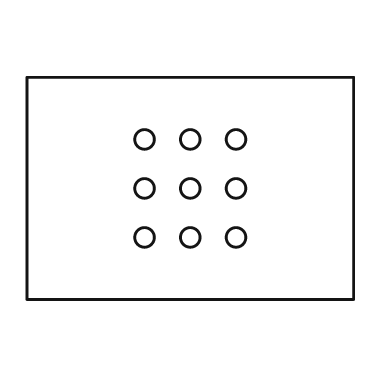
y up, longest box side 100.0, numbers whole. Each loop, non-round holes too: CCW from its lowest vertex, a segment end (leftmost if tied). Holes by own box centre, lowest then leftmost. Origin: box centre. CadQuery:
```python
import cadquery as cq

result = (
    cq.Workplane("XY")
    .moveTo(-50.0, -34.0)
    .lineTo(50.0, -34.0)
    .lineTo(50.0, 34.0)
    .lineTo(-50.0, 34.0)
    .close()
    .moveTo(-14.0, -15.0)
    .circle(3.0)
    .moveTo(0.0, -15.0)
    .circle(3.0)
    .moveTo(14.0, -15.0)
    .circle(3.0)
    .moveTo(-14.0, 0.0)
    .circle(3.0)
    .moveTo(0.0, 0.0)
    .circle(3.0)
    .moveTo(14.0, 0.0)
    .circle(3.0)
    .moveTo(-14.0, 15.0)
    .circle(3.0)
    .moveTo(0.0, 15.0)
    .circle(3.0)
    .moveTo(14.0, 15.0)
    .circle(3.0)
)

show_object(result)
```